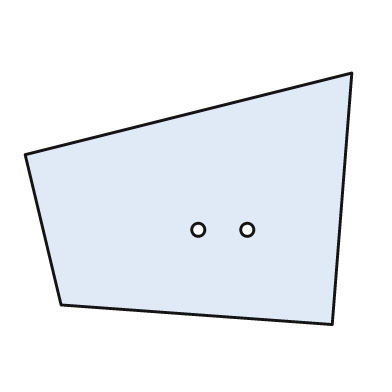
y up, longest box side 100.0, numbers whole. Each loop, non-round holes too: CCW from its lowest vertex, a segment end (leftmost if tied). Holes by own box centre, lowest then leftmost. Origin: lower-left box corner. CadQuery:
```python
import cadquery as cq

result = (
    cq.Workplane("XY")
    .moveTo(94.0, 0.0)
    .lineTo(100.0, 77.0)
    .lineTo(0.0, 52.0)
    .lineTo(11.0, 6.0)
    .close()
    .moveTo(53.0, 29.0)
    .circle(2.0)
    .moveTo(68.0, 29.0)
    .circle(2.0)
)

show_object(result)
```